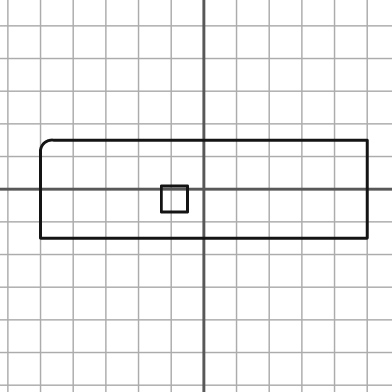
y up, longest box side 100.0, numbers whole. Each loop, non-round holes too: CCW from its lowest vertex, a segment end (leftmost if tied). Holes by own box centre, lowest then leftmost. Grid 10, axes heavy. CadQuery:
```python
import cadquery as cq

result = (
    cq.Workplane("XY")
    .moveTo(-50.0, -15.0)
    .lineTo(50.0, -15.0)
    .lineTo(50.0, 15.0)
    .lineTo(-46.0, 15.0)
    .threePointArc((-49.0, 14.0), (-50.0, 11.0))
    .close()
    .moveTo(-13.0, -7.0)
    .lineTo(-5.0, -7.0)
    .lineTo(-5.0, 1.0)
    .lineTo(-13.0, 1.0)
    .close()
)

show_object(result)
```